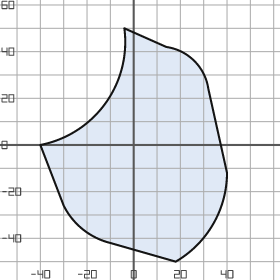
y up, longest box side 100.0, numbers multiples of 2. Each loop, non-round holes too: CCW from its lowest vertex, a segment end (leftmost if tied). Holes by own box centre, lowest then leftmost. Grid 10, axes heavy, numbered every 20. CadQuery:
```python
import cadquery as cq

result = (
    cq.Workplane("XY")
    .moveTo(18.0, -50.0)
    .threePointArc((34.0, -34.0), (40.0, -12.0))
    .lineTo(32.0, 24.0)
    .threePointArc((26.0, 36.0), (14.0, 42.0))
    .lineTo(-4.0, 50.0)
    .threePointArc((-12.0, 18.0), (-40.0, 0.0))
    .lineTo(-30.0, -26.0)
    .threePointArc((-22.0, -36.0), (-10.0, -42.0))
    .close()
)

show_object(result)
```